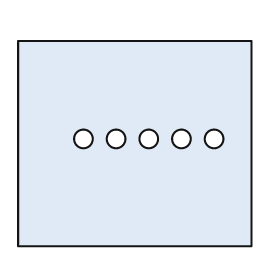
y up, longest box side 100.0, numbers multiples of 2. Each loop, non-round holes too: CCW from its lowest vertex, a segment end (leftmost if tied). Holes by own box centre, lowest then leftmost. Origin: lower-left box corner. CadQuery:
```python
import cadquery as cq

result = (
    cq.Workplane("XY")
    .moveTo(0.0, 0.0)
    .lineTo(100.0, 0.0)
    .lineTo(100.0, 88.0)
    .lineTo(0.0, 88.0)
    .close()
    .moveTo(28.0, 46.0)
    .circle(4.0)
    .moveTo(42.0, 46.0)
    .circle(4.0)
    .moveTo(56.0, 46.0)
    .circle(4.0)
    .moveTo(70.0, 46.0)
    .circle(4.0)
    .moveTo(84.0, 46.0)
    .circle(4.0)
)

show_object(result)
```